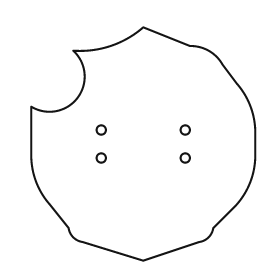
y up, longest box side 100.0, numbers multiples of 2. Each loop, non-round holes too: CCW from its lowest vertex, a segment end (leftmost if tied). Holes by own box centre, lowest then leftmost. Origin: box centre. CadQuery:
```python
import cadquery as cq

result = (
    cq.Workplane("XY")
    .moveTo(0.0, -50.0)
    .lineTo(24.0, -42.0)
    .threePointArc((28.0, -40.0), (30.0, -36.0))
    .lineTo(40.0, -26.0)
    .threePointArc((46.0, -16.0), (48.0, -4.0))
    .lineTo(48.0, 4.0)
    .threePointArc((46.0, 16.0), (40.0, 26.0))
    .lineTo(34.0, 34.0)
    .threePointArc((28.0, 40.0), (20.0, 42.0))
    .lineTo(0.0, 50.0)
    .threePointArc((-14.0, 42.0), (-30.0, 40.0))
    .threePointArc((-28.0, 20.0), (-48.0, 16.0))
    .lineTo(-48.0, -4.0)
    .threePointArc((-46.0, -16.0), (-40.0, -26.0))
    .lineTo(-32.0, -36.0)
    .threePointArc((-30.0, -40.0), (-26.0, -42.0))
    .close()
    .moveTo(-18.0, -6.0)
    .circle(2.0)
    .moveTo(18.0, -6.0)
    .circle(2.0)
    .moveTo(-18.0, 6.0)
    .circle(2.0)
    .moveTo(18.0, 6.0)
    .circle(2.0)
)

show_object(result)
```